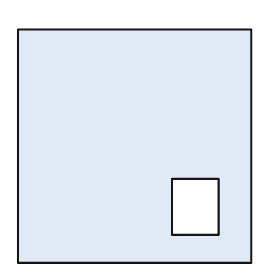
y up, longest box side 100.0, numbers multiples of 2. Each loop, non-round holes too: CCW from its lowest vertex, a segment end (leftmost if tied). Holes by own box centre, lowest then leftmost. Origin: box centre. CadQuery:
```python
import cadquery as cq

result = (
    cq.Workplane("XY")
    .moveTo(-50.0, -50.0)
    .lineTo(50.0, -50.0)
    .lineTo(50.0, 50.0)
    .lineTo(-50.0, 50.0)
    .close()
    .moveTo(16.0, -38.0)
    .lineTo(36.0, -38.0)
    .lineTo(36.0, -14.0)
    .lineTo(16.0, -14.0)
    .close()
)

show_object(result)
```